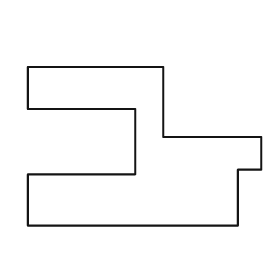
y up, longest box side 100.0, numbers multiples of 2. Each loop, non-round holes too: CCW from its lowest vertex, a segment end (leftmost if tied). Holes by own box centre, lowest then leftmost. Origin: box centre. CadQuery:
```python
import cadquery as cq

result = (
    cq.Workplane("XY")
    .moveTo(-50.0, -34.0)
    .lineTo(40.0, -34.0)
    .lineTo(40.0, -10.0)
    .lineTo(50.0, -10.0)
    .lineTo(50.0, 4.0)
    .lineTo(8.0, 4.0)
    .lineTo(8.0, 34.0)
    .lineTo(-50.0, 34.0)
    .lineTo(-50.0, 16.0)
    .lineTo(-4.0, 16.0)
    .lineTo(-4.0, -12.0)
    .lineTo(-50.0, -12.0)
    .close()
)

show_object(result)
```